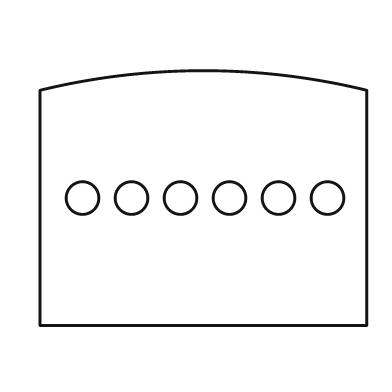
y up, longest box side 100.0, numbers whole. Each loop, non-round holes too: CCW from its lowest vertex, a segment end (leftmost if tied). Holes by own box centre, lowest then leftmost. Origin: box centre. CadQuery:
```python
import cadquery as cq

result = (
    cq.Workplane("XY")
    .moveTo(-50.0, -39.0)
    .lineTo(50.0, -39.0)
    .lineTo(50.0, 33.0)
    .threePointArc((0.0, 39.0), (-50.0, 33.0))
    .close()
    .moveTo(-37.0, 0.0)
    .circle(5.0)
    .moveTo(-22.0, 0.0)
    .circle(5.0)
    .moveTo(-7.0, 0.0)
    .circle(5.0)
    .moveTo(8.0, 0.0)
    .circle(5.0)
    .moveTo(23.0, 0.0)
    .circle(5.0)
    .moveTo(38.0, 0.0)
    .circle(5.0)
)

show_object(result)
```